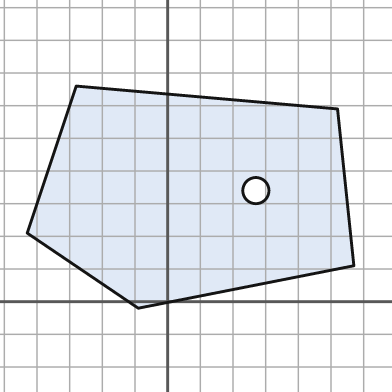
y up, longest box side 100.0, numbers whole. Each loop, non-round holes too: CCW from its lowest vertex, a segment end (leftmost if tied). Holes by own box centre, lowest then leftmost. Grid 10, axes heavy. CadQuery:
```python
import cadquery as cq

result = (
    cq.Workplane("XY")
    .moveTo(-9.0, -2.0)
    .lineTo(57.0, 11.0)
    .lineTo(52.0, 59.0)
    .lineTo(-28.0, 66.0)
    .lineTo(-43.0, 21.0)
    .close()
    .moveTo(27.0, 34.0)
    .circle(4.0)
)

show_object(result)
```